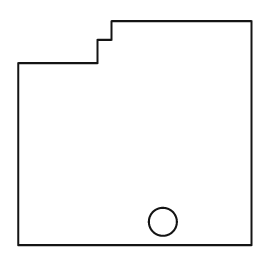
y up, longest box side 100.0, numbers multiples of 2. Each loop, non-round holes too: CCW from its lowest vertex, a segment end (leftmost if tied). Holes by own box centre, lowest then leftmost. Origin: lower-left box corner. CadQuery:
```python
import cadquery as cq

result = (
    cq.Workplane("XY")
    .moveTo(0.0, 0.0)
    .lineTo(100.0, 0.0)
    .lineTo(100.0, 96.0)
    .lineTo(40.0, 96.0)
    .lineTo(40.0, 88.0)
    .lineTo(34.0, 88.0)
    .lineTo(34.0, 78.0)
    .lineTo(0.0, 78.0)
    .close()
    .moveTo(62.0, 10.0)
    .circle(6.0)
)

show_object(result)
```